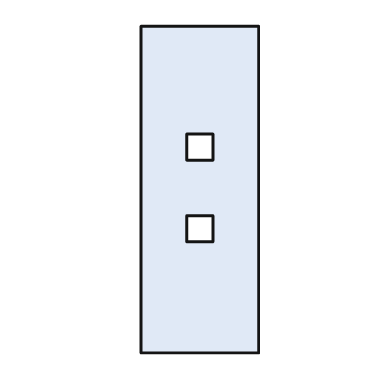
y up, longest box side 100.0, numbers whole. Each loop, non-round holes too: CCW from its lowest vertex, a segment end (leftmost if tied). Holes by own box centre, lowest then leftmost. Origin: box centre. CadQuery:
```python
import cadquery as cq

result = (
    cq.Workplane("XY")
    .moveTo(-18.0, -50.0)
    .lineTo(18.0, -50.0)
    .lineTo(18.0, 50.0)
    .lineTo(-18.0, 50.0)
    .close()
    .moveTo(-4.0, -16.0)
    .lineTo(4.0, -16.0)
    .lineTo(4.0, -8.0)
    .lineTo(-4.0, -8.0)
    .close()
    .moveTo(-4.0, 9.0)
    .lineTo(4.0, 9.0)
    .lineTo(4.0, 17.0)
    .lineTo(-4.0, 17.0)
    .close()
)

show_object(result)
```